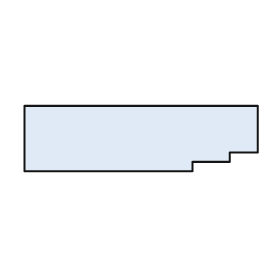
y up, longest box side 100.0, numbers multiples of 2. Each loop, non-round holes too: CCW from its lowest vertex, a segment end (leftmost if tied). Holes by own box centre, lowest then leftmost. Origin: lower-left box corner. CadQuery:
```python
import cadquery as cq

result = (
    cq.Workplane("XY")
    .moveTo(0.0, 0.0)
    .lineTo(72.0, 0.0)
    .lineTo(72.0, 4.0)
    .lineTo(88.0, 4.0)
    .lineTo(88.0, 8.0)
    .lineTo(100.0, 8.0)
    .lineTo(100.0, 28.0)
    .lineTo(0.0, 28.0)
    .close()
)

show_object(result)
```